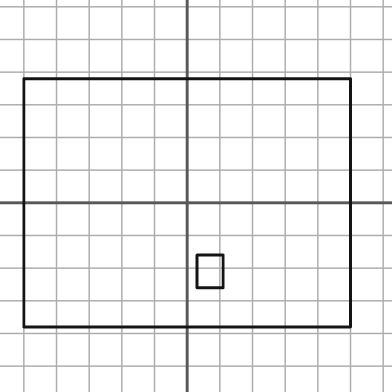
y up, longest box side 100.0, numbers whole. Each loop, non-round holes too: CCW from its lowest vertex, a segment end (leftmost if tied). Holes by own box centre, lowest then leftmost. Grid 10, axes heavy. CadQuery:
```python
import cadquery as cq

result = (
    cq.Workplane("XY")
    .moveTo(-50.0, -38.0)
    .lineTo(50.0, -38.0)
    .lineTo(50.0, 38.0)
    .lineTo(-50.0, 38.0)
    .close()
    .moveTo(3.0, -26.0)
    .lineTo(11.0, -26.0)
    .lineTo(11.0, -16.0)
    .lineTo(3.0, -16.0)
    .close()
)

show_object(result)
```